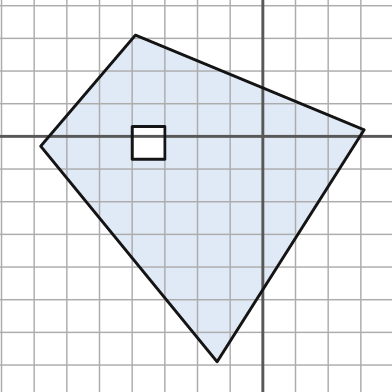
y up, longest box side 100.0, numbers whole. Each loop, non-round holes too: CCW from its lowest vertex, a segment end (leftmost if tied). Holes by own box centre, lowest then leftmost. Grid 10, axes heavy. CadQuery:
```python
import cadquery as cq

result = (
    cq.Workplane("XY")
    .moveTo(-14.0, -69.0)
    .lineTo(31.0, 2.0)
    .lineTo(-39.0, 31.0)
    .lineTo(-68.0, -3.0)
    .close()
    .moveTo(-40.0, -7.0)
    .lineTo(-30.0, -7.0)
    .lineTo(-30.0, 3.0)
    .lineTo(-40.0, 3.0)
    .close()
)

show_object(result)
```